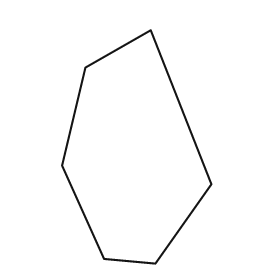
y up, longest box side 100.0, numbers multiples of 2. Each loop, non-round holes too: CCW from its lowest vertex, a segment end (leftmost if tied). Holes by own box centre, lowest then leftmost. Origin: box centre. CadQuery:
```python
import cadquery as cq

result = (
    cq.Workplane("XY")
    .moveTo(8.0, -50.0)
    .lineTo(32.0, -16.0)
    .lineTo(6.0, 50.0)
    .lineTo(-22.0, 34.0)
    .lineTo(-32.0, -8.0)
    .lineTo(-14.0, -48.0)
    .close()
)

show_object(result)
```